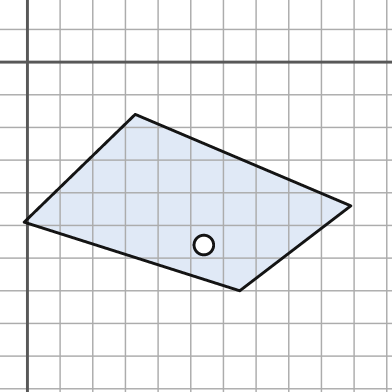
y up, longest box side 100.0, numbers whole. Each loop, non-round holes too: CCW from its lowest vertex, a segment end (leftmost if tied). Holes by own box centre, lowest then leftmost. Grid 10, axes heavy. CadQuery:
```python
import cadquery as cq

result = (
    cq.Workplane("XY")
    .moveTo(65.0, -70.0)
    .lineTo(99.0, -44.0)
    .lineTo(33.0, -16.0)
    .lineTo(-1.0, -49.0)
    .close()
    .moveTo(54.0, -56.0)
    .circle(3.0)
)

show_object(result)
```